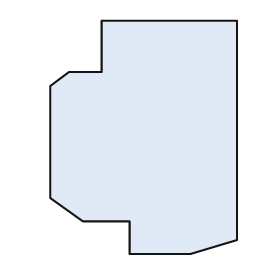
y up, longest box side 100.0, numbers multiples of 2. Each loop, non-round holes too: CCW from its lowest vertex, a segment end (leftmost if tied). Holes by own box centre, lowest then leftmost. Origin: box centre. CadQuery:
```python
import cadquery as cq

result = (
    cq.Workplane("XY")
    .moveTo(-6.0, -50.0)
    .lineTo(20.0, -50.0)
    .lineTo(40.0, -44.0)
    .lineTo(40.0, 50.0)
    .lineTo(-18.0, 50.0)
    .lineTo(-18.0, 28.0)
    .lineTo(-32.0, 28.0)
    .lineTo(-40.0, 22.0)
    .lineTo(-40.0, -26.0)
    .lineTo(-26.0, -36.0)
    .lineTo(-6.0, -36.0)
    .close()
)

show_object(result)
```